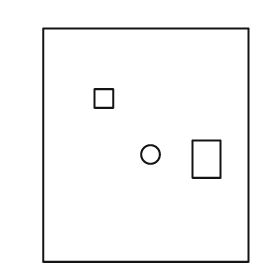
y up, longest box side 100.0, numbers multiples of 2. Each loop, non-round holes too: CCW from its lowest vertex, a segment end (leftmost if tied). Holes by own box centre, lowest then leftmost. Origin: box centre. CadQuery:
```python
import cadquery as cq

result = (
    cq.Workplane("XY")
    .moveTo(-44.0, -50.0)
    .lineTo(44.0, -50.0)
    .lineTo(44.0, 50.0)
    .lineTo(-44.0, 50.0)
    .close()
    .moveTo(20.0, -14.0)
    .lineTo(32.0, -14.0)
    .lineTo(32.0, 2.0)
    .lineTo(20.0, 2.0)
    .close()
    .moveTo(2.0, -4.0)
    .circle(4.0)
    .moveTo(-22.0, 16.0)
    .lineTo(-14.0, 16.0)
    .lineTo(-14.0, 24.0)
    .lineTo(-22.0, 24.0)
    .close()
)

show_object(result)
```